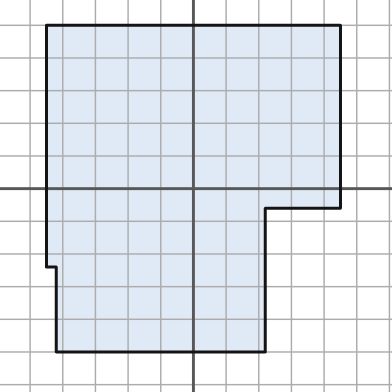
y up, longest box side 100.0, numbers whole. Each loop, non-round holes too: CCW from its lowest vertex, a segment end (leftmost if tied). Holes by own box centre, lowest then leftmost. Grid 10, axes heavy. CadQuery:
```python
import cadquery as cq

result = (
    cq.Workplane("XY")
    .moveTo(-42.0, -50.0)
    .lineTo(22.0, -50.0)
    .lineTo(22.0, -6.0)
    .lineTo(45.0, -6.0)
    .lineTo(45.0, 50.0)
    .lineTo(-45.0, 50.0)
    .lineTo(-45.0, -24.0)
    .lineTo(-42.0, -24.0)
    .close()
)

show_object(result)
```